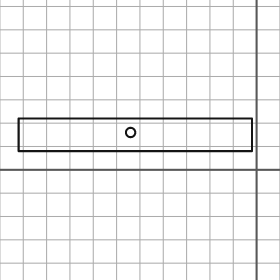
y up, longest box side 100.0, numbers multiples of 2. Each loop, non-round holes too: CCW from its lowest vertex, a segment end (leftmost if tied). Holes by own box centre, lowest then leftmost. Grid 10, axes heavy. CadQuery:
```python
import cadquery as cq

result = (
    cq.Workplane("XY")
    .moveTo(-102.0, 8.0)
    .lineTo(-2.0, 8.0)
    .lineTo(-2.0, 22.0)
    .lineTo(-102.0, 22.0)
    .close()
    .moveTo(-54.0, 16.0)
    .circle(2.0)
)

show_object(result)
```